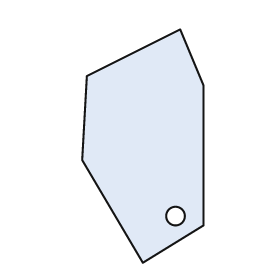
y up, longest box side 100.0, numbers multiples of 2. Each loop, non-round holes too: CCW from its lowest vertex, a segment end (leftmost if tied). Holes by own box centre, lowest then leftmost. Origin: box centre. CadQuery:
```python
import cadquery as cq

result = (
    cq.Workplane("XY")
    .moveTo(0.0, -50.0)
    .lineTo(26.0, -34.0)
    .lineTo(26.0, 26.0)
    .lineTo(16.0, 50.0)
    .lineTo(-24.0, 30.0)
    .lineTo(-26.0, -6.0)
    .close()
    .moveTo(14.0, -30.0)
    .circle(4.0)
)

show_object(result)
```